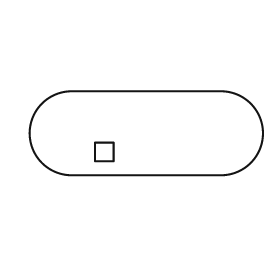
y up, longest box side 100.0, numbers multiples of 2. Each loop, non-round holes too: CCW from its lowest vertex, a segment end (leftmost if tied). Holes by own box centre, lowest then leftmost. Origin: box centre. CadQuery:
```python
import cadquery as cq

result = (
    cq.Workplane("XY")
    .moveTo(-32.0, -18.0)
    .lineTo(32.0, -18.0)
    .threePointArc((50.0, 0.0), (32.0, 18.0))
    .lineTo(-32.0, 18.0)
    .threePointArc((-50.0, 0.0), (-32.0, -18.0))
    .close()
    .moveTo(-22.0, -12.0)
    .lineTo(-14.0, -12.0)
    .lineTo(-14.0, -4.0)
    .lineTo(-22.0, -4.0)
    .close()
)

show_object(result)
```